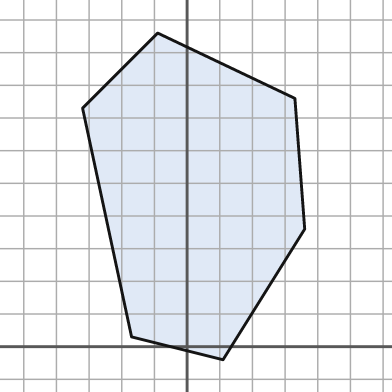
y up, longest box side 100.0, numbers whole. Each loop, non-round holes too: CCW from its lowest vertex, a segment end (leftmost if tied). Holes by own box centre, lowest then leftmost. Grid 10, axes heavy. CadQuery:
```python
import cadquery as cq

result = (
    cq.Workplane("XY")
    .moveTo(11.0, -4.0)
    .lineTo(36.0, 36.0)
    .lineTo(33.0, 76.0)
    .lineTo(-9.0, 96.0)
    .lineTo(-32.0, 73.0)
    .lineTo(-17.0, 3.0)
    .close()
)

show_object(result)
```